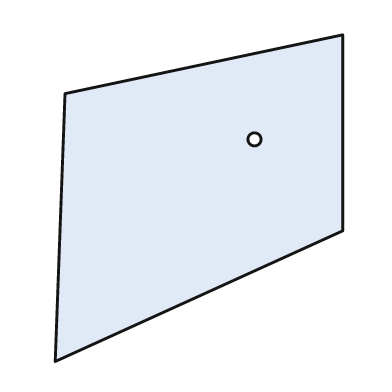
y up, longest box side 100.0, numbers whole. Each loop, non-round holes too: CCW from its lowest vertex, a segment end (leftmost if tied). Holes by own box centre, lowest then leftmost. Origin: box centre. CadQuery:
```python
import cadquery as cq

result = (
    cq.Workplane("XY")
    .moveTo(-44.0, -50.0)
    .lineTo(44.0, -10.0)
    .lineTo(44.0, 50.0)
    .lineTo(-41.0, 32.0)
    .close()
    .moveTo(17.0, 18.0)
    .circle(2.0)
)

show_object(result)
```